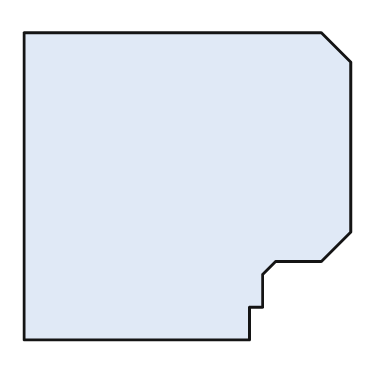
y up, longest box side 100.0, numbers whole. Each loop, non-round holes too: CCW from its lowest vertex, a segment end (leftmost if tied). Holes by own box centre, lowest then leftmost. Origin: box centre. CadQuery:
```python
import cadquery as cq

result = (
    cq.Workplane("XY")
    .moveTo(-50.0, -47.0)
    .lineTo(19.0, -47.0)
    .lineTo(19.0, -37.0)
    .lineTo(23.0, -37.0)
    .lineTo(23.0, -27.0)
    .lineTo(27.0, -23.0)
    .lineTo(41.0, -23.0)
    .lineTo(50.0, -14.0)
    .lineTo(50.0, 38.0)
    .lineTo(41.0, 47.0)
    .lineTo(-50.0, 47.0)
    .close()
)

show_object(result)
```